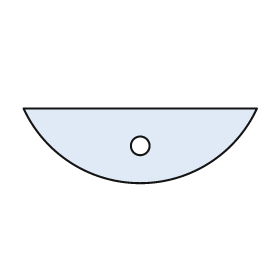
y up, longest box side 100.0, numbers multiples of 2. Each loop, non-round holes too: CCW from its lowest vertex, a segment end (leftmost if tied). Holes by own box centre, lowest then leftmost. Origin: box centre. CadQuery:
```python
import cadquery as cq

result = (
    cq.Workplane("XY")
    .moveTo(-50.0, 16.0)
    .threePointArc((0.0, -16.0), (50.0, 16.0))
    .close()
    .moveTo(0.0, 0.0)
    .circle(4.0)
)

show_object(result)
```